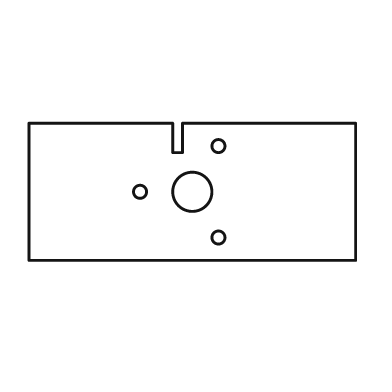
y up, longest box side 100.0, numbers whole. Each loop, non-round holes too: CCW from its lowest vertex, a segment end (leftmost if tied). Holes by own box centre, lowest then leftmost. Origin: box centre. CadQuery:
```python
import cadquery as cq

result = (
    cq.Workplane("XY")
    .moveTo(-50.0, -21.0)
    .lineTo(50.0, -21.0)
    .lineTo(50.0, 21.0)
    .lineTo(-3.0, 21.0)
    .lineTo(-3.0, 12.0)
    .lineTo(-6.0, 12.0)
    .lineTo(-6.0, 21.0)
    .lineTo(-50.0, 21.0)
    .close()
    .moveTo(8.0, -14.0)
    .circle(2.0)
    .moveTo(-16.0, 0.0)
    .circle(2.0)
    .moveTo(0.0, 0.0)
    .circle(6.0)
    .moveTo(8.0, 14.0)
    .circle(2.0)
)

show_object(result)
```